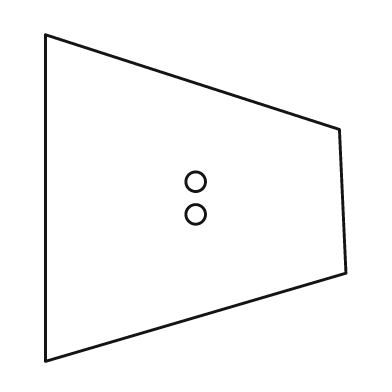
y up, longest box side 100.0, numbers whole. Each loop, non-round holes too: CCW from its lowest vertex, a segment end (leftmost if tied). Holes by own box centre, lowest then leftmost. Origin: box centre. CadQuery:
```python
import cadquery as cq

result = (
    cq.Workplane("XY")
    .moveTo(-46.0, -50.0)
    .lineTo(46.0, -23.0)
    .lineTo(44.0, 21.0)
    .lineTo(-46.0, 50.0)
    .close()
    .moveTo(0.0, -5.0)
    .circle(3.0)
    .moveTo(0.0, 5.0)
    .circle(3.0)
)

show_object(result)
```